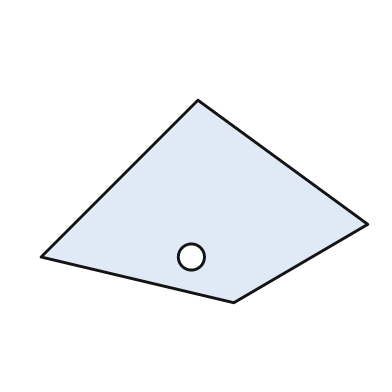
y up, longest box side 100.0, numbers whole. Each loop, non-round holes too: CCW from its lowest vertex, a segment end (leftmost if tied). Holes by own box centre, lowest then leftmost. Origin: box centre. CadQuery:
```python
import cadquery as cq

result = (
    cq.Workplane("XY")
    .moveTo(9.0, -31.0)
    .lineTo(50.0, -7.0)
    .lineTo(-2.0, 31.0)
    .lineTo(-50.0, -17.0)
    .close()
    .moveTo(-4.0, -17.0)
    .circle(4.0)
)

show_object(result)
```